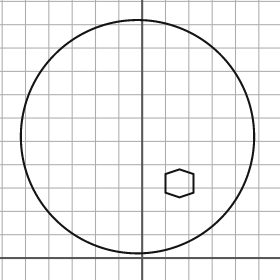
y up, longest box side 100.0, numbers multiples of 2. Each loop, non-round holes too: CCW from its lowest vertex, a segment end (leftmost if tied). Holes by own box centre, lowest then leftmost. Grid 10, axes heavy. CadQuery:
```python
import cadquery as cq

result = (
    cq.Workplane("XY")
    .moveTo(-2.0, 52.0)
    .circle(50.0)
    .moveTo(16.0, 26.0)
    .lineTo(22.0, 28.0)
    .lineTo(22.0, 36.0)
    .lineTo(16.0, 38.0)
    .lineTo(10.0, 36.0)
    .lineTo(10.0, 28.0)
    .close()
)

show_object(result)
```